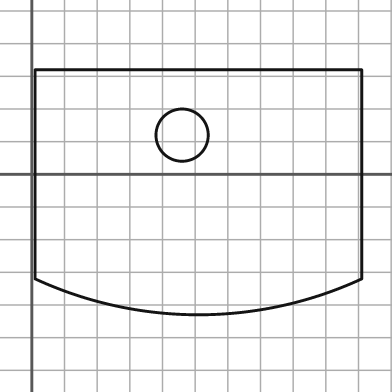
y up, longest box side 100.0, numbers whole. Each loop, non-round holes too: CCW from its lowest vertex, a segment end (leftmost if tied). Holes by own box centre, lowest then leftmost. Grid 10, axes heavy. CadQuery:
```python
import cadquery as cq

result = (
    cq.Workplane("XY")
    .moveTo(1.0, -32.0)
    .threePointArc((51.0, -43.0), (101.0, -32.0))
    .lineTo(101.0, 32.0)
    .lineTo(1.0, 32.0)
    .close()
    .moveTo(46.0, 12.0)
    .circle(8.0)
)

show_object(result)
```